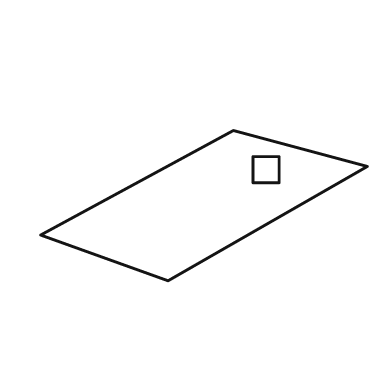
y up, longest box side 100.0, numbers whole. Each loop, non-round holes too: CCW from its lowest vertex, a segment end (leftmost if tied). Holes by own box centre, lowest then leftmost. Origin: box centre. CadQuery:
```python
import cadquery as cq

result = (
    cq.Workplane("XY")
    .moveTo(-11.0, -23.0)
    .lineTo(50.0, 12.0)
    .lineTo(9.0, 23.0)
    .lineTo(-50.0, -9.0)
    .close()
    .moveTo(15.0, 7.0)
    .lineTo(23.0, 7.0)
    .lineTo(23.0, 15.0)
    .lineTo(15.0, 15.0)
    .close()
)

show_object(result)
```